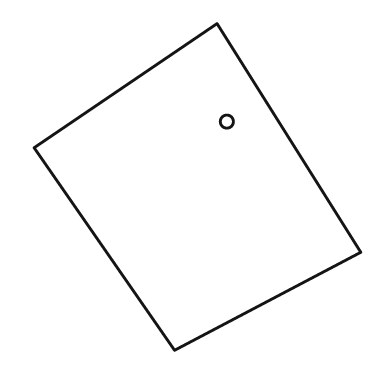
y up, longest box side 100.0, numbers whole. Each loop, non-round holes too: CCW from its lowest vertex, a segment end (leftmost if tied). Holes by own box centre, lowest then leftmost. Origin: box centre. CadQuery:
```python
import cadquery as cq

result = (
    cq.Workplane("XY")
    .moveTo(-7.0, -50.0)
    .lineTo(50.0, -20.0)
    .lineTo(6.0, 50.0)
    .lineTo(-50.0, 12.0)
    .close()
    .moveTo(9.0, 20.0)
    .circle(2.0)
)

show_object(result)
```